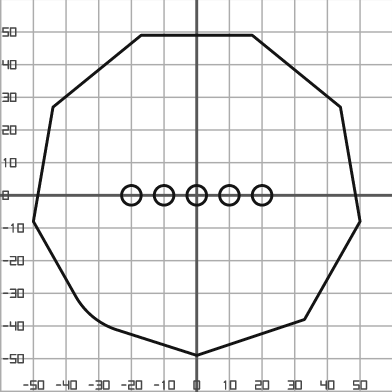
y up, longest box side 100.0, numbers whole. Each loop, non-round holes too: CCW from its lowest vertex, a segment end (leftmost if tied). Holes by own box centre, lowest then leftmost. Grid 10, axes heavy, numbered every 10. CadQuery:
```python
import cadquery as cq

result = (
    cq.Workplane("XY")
    .moveTo(0.0, -49.0)
    .lineTo(33.0, -38.0)
    .lineTo(50.0, -8.0)
    .lineTo(44.0, 27.0)
    .lineTo(17.0, 49.0)
    .lineTo(-17.0, 49.0)
    .lineTo(-44.0, 27.0)
    .lineTo(-50.0, -8.0)
    .lineTo(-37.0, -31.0)
    .threePointArc((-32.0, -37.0), (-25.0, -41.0))
    .close()
    .moveTo(-20.0, 0.0)
    .circle(3.0)
    .moveTo(-10.0, 0.0)
    .circle(3.0)
    .moveTo(0.0, 0.0)
    .circle(3.0)
    .moveTo(10.0, 0.0)
    .circle(3.0)
    .moveTo(20.0, 0.0)
    .circle(3.0)
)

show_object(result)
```